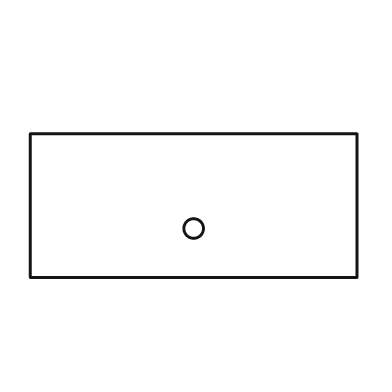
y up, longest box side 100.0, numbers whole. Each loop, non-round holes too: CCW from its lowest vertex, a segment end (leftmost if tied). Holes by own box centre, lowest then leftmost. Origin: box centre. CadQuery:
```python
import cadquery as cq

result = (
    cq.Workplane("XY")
    .moveTo(-50.0, -22.0)
    .lineTo(50.0, -22.0)
    .lineTo(50.0, 22.0)
    .lineTo(-50.0, 22.0)
    .close()
    .moveTo(0.0, -7.0)
    .circle(3.0)
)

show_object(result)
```